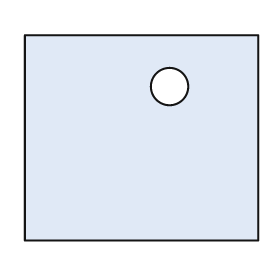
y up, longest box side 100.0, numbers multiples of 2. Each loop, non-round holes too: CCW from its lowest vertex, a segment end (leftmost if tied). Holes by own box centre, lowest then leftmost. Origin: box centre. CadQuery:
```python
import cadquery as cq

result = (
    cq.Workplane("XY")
    .moveTo(-50.0, -44.0)
    .lineTo(50.0, -44.0)
    .lineTo(50.0, 44.0)
    .lineTo(-50.0, 44.0)
    .close()
    .moveTo(12.0, 22.0)
    .circle(8.0)
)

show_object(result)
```